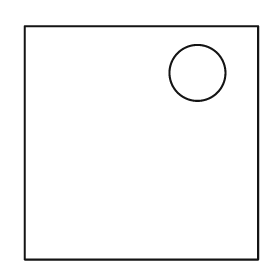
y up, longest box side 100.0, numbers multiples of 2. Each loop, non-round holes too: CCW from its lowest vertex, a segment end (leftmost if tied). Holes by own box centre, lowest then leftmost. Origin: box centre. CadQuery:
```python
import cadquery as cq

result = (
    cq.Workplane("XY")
    .moveTo(-50.0, -50.0)
    .lineTo(50.0, -50.0)
    .lineTo(50.0, 50.0)
    .lineTo(-50.0, 50.0)
    .close()
    .moveTo(24.0, 30.0)
    .circle(12.0)
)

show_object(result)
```